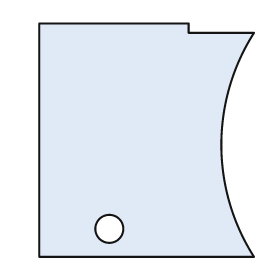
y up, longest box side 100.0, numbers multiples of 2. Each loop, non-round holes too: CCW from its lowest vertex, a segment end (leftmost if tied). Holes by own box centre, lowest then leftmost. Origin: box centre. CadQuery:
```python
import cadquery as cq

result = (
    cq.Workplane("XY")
    .moveTo(-46.0, -50.0)
    .lineTo(46.0, -50.0)
    .threePointArc((32.0, -2.0), (46.0, 46.0))
    .lineTo(18.0, 46.0)
    .lineTo(18.0, 50.0)
    .lineTo(-46.0, 50.0)
    .close()
    .moveTo(-16.0, -38.0)
    .circle(6.0)
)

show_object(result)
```